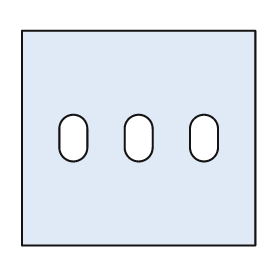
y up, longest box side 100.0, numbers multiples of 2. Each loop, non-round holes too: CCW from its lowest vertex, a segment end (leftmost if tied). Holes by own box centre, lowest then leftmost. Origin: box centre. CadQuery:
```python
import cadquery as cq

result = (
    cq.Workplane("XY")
    .moveTo(-50.0, -46.0)
    .lineTo(50.0, -46.0)
    .lineTo(50.0, 46.0)
    .lineTo(-50.0, 46.0)
    .close()
    .moveTo(-34.0, -4.0)
    .threePointArc((-28.0, -10.0), (-22.0, -4.0))
    .lineTo(-22.0, 4.0)
    .threePointArc((-28.0, 10.0), (-34.0, 4.0))
    .close()
    .moveTo(-6.0, -4.0)
    .threePointArc((0.0, -10.0), (6.0, -4.0))
    .lineTo(6.0, 4.0)
    .threePointArc((0.0, 10.0), (-6.0, 4.0))
    .close()
    .moveTo(22.0, -4.0)
    .threePointArc((28.0, -10.0), (34.0, -4.0))
    .lineTo(34.0, 4.0)
    .threePointArc((28.0, 10.0), (22.0, 4.0))
    .close()
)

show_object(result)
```